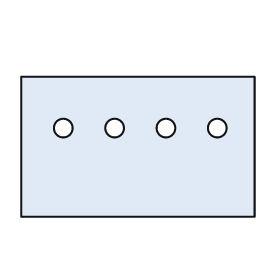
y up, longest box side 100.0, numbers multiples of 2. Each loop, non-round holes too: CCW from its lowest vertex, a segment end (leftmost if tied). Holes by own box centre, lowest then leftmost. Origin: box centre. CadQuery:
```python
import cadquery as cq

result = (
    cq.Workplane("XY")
    .moveTo(-50.0, -30.0)
    .lineTo(50.0, -30.0)
    .lineTo(50.0, 30.0)
    .lineTo(-50.0, 30.0)
    .close()
    .moveTo(-32.0, 8.0)
    .circle(4.0)
    .moveTo(-10.0, 8.0)
    .circle(4.0)
    .moveTo(12.0, 8.0)
    .circle(4.0)
    .moveTo(34.0, 8.0)
    .circle(4.0)
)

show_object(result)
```